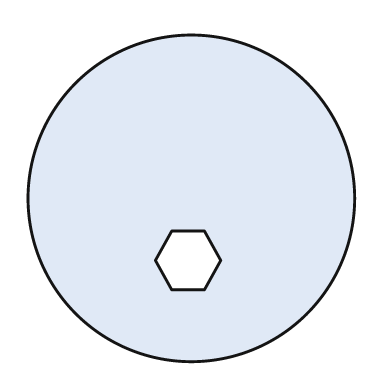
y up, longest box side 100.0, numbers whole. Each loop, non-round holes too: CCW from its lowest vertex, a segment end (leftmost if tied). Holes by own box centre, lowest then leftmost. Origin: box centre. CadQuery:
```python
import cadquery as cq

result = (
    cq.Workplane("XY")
    .moveTo(0.0, 0.0)
    .circle(50.0)
    .moveTo(-6.0, -28.0)
    .lineTo(4.0, -28.0)
    .lineTo(9.0, -19.0)
    .lineTo(4.0, -10.0)
    .lineTo(-6.0, -10.0)
    .lineTo(-11.0, -19.0)
    .close()
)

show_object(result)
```